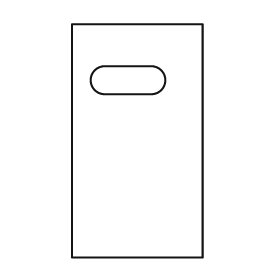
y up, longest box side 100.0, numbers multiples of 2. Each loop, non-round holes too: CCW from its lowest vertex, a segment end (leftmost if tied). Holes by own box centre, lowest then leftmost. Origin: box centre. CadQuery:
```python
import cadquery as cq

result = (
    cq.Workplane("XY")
    .moveTo(-28.0, -50.0)
    .lineTo(28.0, -50.0)
    .lineTo(28.0, 50.0)
    .lineTo(-28.0, 50.0)
    .close()
    .moveTo(-14.0, 20.0)
    .lineTo(6.0, 20.0)
    .threePointArc((12.0, 26.0), (6.0, 32.0))
    .lineTo(-14.0, 32.0)
    .threePointArc((-20.0, 26.0), (-14.0, 20.0))
    .close()
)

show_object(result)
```